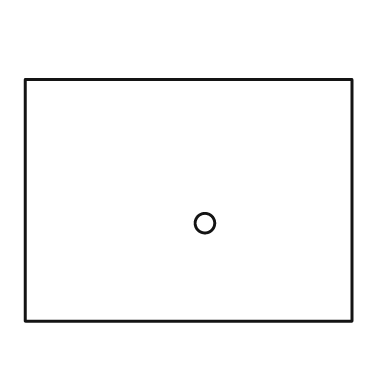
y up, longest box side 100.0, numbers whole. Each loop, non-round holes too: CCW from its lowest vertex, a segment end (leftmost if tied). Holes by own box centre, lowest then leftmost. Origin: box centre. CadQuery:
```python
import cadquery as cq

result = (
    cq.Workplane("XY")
    .moveTo(-50.0, -37.0)
    .lineTo(50.0, -37.0)
    .lineTo(50.0, 37.0)
    .lineTo(-50.0, 37.0)
    .close()
    .moveTo(5.0, -7.0)
    .circle(3.0)
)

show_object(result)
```